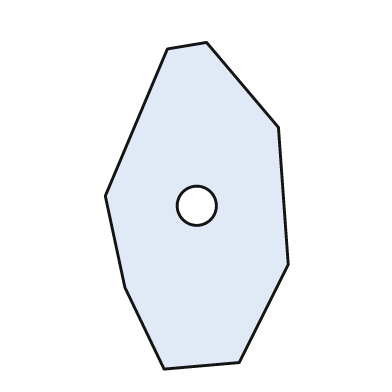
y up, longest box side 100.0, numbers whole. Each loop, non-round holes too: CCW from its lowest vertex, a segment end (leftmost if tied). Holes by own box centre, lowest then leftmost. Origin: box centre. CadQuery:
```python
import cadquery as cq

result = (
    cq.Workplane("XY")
    .moveTo(-10.0, -50.0)
    .lineTo(13.0, -48.0)
    .lineTo(28.0, -18.0)
    .lineTo(25.0, 24.0)
    .lineTo(3.0, 50.0)
    .lineTo(-9.0, 48.0)
    .lineTo(-28.0, 3.0)
    .lineTo(-22.0, -25.0)
    .close()
    .moveTo(0.0, 0.0)
    .circle(6.0)
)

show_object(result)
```